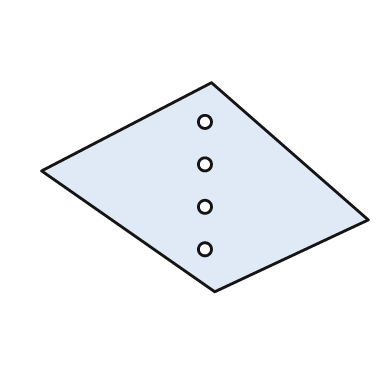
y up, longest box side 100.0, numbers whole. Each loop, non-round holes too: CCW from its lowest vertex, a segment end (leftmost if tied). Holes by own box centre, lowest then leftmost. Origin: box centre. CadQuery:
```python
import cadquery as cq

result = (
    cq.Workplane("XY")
    .moveTo(3.0, -32.0)
    .lineTo(50.0, -10.0)
    .lineTo(2.0, 32.0)
    .lineTo(-50.0, 5.0)
    .close()
    .moveTo(0.0, -19.0)
    .circle(2.0)
    .moveTo(0.0, -6.0)
    .circle(2.0)
    .moveTo(0.0, 7.0)
    .circle(2.0)
    .moveTo(0.0, 20.0)
    .circle(2.0)
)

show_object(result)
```